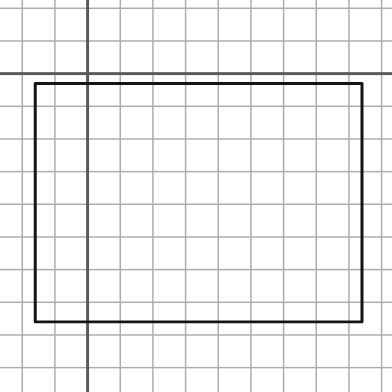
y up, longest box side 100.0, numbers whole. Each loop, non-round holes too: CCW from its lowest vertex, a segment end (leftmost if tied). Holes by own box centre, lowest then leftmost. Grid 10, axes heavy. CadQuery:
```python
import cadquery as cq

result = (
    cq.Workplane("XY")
    .moveTo(-16.0, -76.0)
    .lineTo(84.0, -76.0)
    .lineTo(84.0, -3.0)
    .lineTo(-16.0, -3.0)
    .close()
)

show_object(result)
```